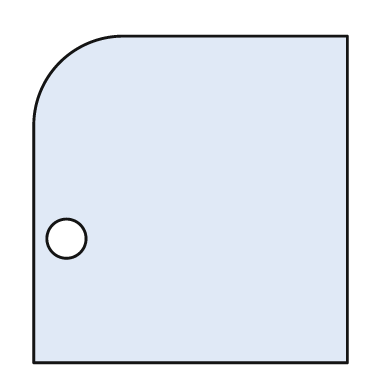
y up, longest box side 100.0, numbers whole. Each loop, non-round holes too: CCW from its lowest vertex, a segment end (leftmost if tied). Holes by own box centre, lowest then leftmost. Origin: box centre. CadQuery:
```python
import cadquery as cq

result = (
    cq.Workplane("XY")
    .moveTo(-48.0, -50.0)
    .lineTo(48.0, -50.0)
    .lineTo(48.0, 50.0)
    .lineTo(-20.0, 50.0)
    .threePointArc((-40.0, 42.0), (-48.0, 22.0))
    .close()
    .moveTo(-38.0, -12.0)
    .circle(6.0)
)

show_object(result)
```